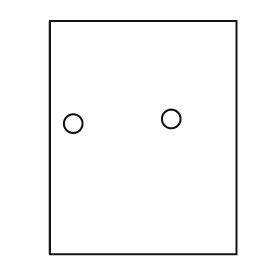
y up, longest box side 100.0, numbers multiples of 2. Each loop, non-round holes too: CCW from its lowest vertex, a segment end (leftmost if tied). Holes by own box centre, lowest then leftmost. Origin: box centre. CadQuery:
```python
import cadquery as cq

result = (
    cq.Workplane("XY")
    .moveTo(-40.0, -50.0)
    .lineTo(40.0, -50.0)
    .lineTo(40.0, 50.0)
    .lineTo(-40.0, 50.0)
    .close()
    .moveTo(-30.0, 6.0)
    .circle(4.0)
    .moveTo(12.0, 8.0)
    .circle(4.0)
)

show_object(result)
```